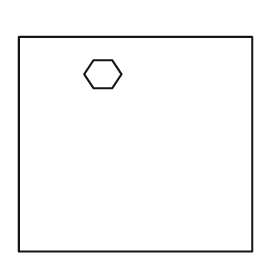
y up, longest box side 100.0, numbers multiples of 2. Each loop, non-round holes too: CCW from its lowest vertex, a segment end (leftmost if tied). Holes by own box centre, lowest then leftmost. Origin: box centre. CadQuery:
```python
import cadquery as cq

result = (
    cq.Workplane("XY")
    .moveTo(-50.0, -46.0)
    .lineTo(50.0, -46.0)
    .lineTo(50.0, 46.0)
    .lineTo(-50.0, 46.0)
    .close()
    .moveTo(-18.0, 24.0)
    .lineTo(-10.0, 24.0)
    .lineTo(-6.0, 30.0)
    .lineTo(-10.0, 36.0)
    .lineTo(-18.0, 36.0)
    .lineTo(-22.0, 30.0)
    .close()
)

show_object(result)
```